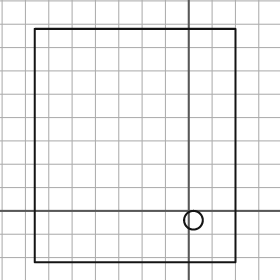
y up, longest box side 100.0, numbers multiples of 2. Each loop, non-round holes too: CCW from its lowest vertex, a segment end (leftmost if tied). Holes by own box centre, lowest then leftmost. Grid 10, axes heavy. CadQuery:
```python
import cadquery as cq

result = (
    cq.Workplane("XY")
    .moveTo(-66.0, -22.0)
    .lineTo(20.0, -22.0)
    .lineTo(20.0, 78.0)
    .lineTo(-66.0, 78.0)
    .close()
    .moveTo(2.0, -4.0)
    .circle(4.0)
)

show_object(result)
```